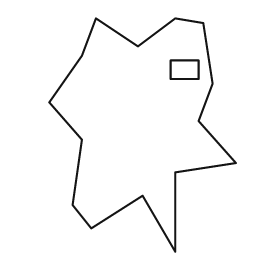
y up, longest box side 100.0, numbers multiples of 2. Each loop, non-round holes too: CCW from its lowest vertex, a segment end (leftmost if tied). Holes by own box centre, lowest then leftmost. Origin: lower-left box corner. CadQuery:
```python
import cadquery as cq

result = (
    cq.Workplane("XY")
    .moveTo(54.0, 0.0)
    .lineTo(54.0, 34.0)
    .lineTo(80.0, 38.0)
    .lineTo(64.0, 56.0)
    .lineTo(70.0, 72.0)
    .lineTo(66.0, 98.0)
    .lineTo(54.0, 100.0)
    .lineTo(38.0, 88.0)
    .lineTo(20.0, 100.0)
    .lineTo(14.0, 84.0)
    .lineTo(0.0, 64.0)
    .lineTo(14.0, 48.0)
    .lineTo(10.0, 20.0)
    .lineTo(18.0, 10.0)
    .lineTo(40.0, 24.0)
    .close()
    .moveTo(52.0, 74.0)
    .lineTo(64.0, 74.0)
    .lineTo(64.0, 82.0)
    .lineTo(52.0, 82.0)
    .close()
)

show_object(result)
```